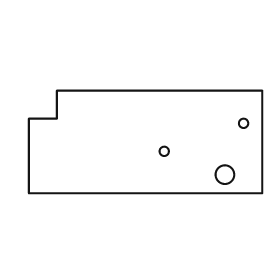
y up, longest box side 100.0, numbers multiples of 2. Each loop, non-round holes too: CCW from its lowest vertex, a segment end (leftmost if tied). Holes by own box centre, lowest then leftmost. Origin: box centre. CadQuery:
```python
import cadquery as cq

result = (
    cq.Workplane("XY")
    .moveTo(-50.0, -22.0)
    .lineTo(50.0, -22.0)
    .lineTo(50.0, 22.0)
    .lineTo(-38.0, 22.0)
    .lineTo(-38.0, 10.0)
    .lineTo(-50.0, 10.0)
    .close()
    .moveTo(34.0, -14.0)
    .circle(4.0)
    .moveTo(8.0, -4.0)
    .circle(2.0)
    .moveTo(42.0, 8.0)
    .circle(2.0)
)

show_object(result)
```